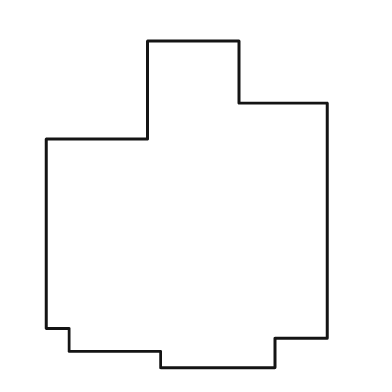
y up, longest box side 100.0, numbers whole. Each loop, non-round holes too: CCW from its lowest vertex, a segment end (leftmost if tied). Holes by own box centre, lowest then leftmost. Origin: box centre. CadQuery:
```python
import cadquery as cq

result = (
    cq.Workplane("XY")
    .moveTo(-8.0, -50.0)
    .lineTo(27.0, -50.0)
    .lineTo(27.0, -41.0)
    .lineTo(43.0, -41.0)
    .lineTo(43.0, 31.0)
    .lineTo(16.0, 31.0)
    .lineTo(16.0, 50.0)
    .lineTo(-12.0, 50.0)
    .lineTo(-12.0, 20.0)
    .lineTo(-43.0, 20.0)
    .lineTo(-43.0, -38.0)
    .lineTo(-36.0, -38.0)
    .lineTo(-36.0, -45.0)
    .lineTo(-8.0, -45.0)
    .close()
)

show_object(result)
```